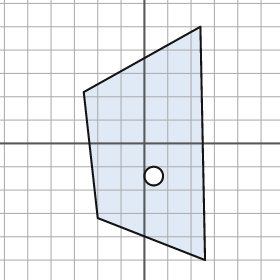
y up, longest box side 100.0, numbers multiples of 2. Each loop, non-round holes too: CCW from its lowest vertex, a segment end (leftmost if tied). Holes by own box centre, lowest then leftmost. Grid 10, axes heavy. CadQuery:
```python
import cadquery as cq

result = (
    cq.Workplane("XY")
    .moveTo(26.0, -50.0)
    .lineTo(24.0, 50.0)
    .lineTo(-26.0, 22.0)
    .lineTo(-20.0, -32.0)
    .close()
    .moveTo(4.0, -14.0)
    .circle(4.0)
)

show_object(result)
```